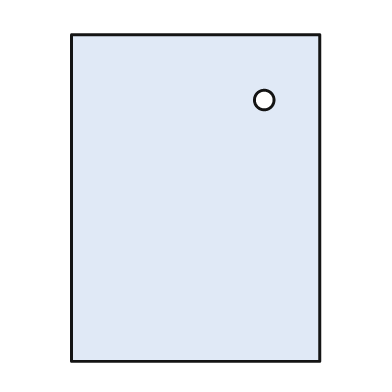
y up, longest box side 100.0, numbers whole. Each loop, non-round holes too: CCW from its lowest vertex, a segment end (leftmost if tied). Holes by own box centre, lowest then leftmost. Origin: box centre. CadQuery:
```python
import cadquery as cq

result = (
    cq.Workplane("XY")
    .moveTo(-38.0, -50.0)
    .lineTo(38.0, -50.0)
    .lineTo(38.0, 50.0)
    .lineTo(-38.0, 50.0)
    .close()
    .moveTo(21.0, 30.0)
    .circle(3.0)
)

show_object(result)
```